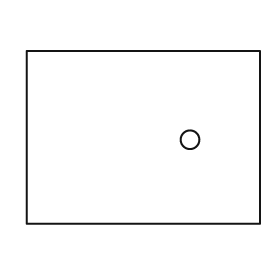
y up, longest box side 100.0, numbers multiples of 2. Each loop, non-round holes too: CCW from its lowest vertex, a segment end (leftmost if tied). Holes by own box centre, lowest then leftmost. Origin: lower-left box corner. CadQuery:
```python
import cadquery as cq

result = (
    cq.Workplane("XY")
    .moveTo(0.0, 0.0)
    .lineTo(100.0, 0.0)
    .lineTo(100.0, 74.0)
    .lineTo(0.0, 74.0)
    .close()
    .moveTo(70.0, 36.0)
    .circle(4.0)
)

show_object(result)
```